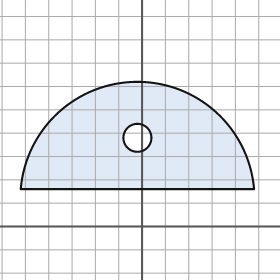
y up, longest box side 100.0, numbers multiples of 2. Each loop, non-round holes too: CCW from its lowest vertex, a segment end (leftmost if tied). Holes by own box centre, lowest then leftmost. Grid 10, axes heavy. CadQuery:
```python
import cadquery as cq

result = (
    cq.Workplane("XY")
    .moveTo(-52.0, 16.0)
    .lineTo(48.0, 16.0)
    .threePointArc((-2.0, 62.0), (-52.0, 16.0))
    .close()
    .moveTo(-2.0, 38.0)
    .circle(6.0)
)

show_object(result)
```